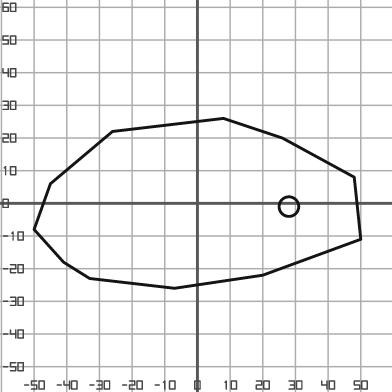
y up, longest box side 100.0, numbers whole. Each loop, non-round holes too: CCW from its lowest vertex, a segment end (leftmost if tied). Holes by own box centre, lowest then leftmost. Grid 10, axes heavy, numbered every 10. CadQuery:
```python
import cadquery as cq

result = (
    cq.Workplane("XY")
    .moveTo(-7.0, -26.0)
    .lineTo(20.0, -22.0)
    .lineTo(50.0, -11.0)
    .lineTo(48.0, 8.0)
    .lineTo(26.0, 20.0)
    .lineTo(8.0, 26.0)
    .lineTo(-26.0, 22.0)
    .lineTo(-45.0, 6.0)
    .lineTo(-50.0, -8.0)
    .lineTo(-41.0, -18.0)
    .lineTo(-33.0, -23.0)
    .close()
    .moveTo(28.0, -1.0)
    .circle(3.0)
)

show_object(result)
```